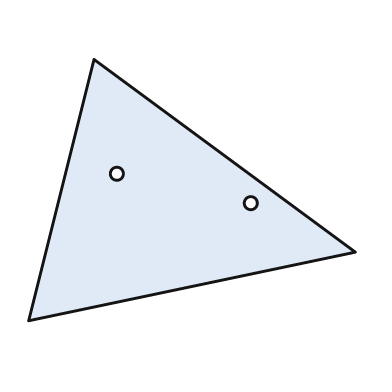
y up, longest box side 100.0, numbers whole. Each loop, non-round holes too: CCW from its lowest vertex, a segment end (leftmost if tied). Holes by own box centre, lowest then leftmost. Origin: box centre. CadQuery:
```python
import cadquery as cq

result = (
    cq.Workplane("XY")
    .moveTo(-50.0, -40.0)
    .lineTo(50.0, -19.0)
    .lineTo(-30.0, 40.0)
    .close()
    .moveTo(18.0, -4.0)
    .circle(2.0)
    .moveTo(-23.0, 5.0)
    .circle(2.0)
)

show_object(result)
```